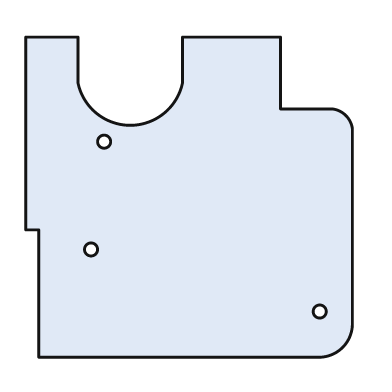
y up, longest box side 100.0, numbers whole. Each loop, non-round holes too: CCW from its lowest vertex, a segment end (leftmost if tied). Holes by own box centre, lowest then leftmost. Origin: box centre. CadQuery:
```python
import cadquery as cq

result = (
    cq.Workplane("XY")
    .moveTo(-46.0, -49.0)
    .lineTo(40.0, -49.0)
    .threePointArc((47.0, -46.0), (50.0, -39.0))
    .lineTo(50.0, 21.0)
    .threePointArc((48.0, 25.0), (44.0, 27.0))
    .lineTo(28.0, 27.0)
    .lineTo(28.0, 49.0)
    .lineTo(-2.0, 49.0)
    .lineTo(-2.0, 35.0)
    .threePointArc((-18.0, 22.0), (-34.0, 35.0))
    .lineTo(-34.0, 49.0)
    .lineTo(-50.0, 49.0)
    .lineTo(-50.0, -10.0)
    .lineTo(-46.0, -10.0)
    .close()
    .moveTo(40.0, -35.0)
    .circle(2.0)
    .moveTo(-30.0, -16.0)
    .circle(2.0)
    .moveTo(-26.0, 17.0)
    .circle(2.0)
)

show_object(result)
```